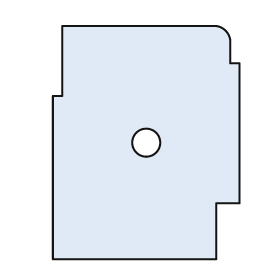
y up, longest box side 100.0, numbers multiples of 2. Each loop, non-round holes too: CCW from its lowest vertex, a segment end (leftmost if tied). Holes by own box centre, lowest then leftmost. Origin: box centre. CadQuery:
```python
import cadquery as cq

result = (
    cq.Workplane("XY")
    .moveTo(-40.0, -50.0)
    .lineTo(30.0, -50.0)
    .lineTo(30.0, -26.0)
    .lineTo(40.0, -26.0)
    .lineTo(40.0, 34.0)
    .lineTo(36.0, 34.0)
    .lineTo(36.0, 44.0)
    .threePointArc((34.0, 48.0), (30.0, 50.0))
    .lineTo(-36.0, 50.0)
    .lineTo(-36.0, 20.0)
    .lineTo(-40.0, 20.0)
    .close()
    .moveTo(0.0, 0.0)
    .circle(6.0)
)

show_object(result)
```